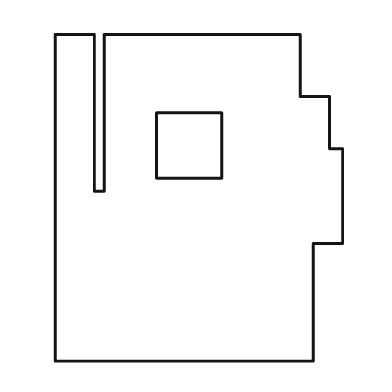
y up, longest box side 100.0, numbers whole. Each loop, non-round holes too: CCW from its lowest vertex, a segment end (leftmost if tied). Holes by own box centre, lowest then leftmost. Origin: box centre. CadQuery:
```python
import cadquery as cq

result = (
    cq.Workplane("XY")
    .moveTo(-44.0, -50.0)
    .lineTo(35.0, -50.0)
    .lineTo(35.0, -14.0)
    .lineTo(44.0, -14.0)
    .lineTo(44.0, 15.0)
    .lineTo(40.0, 15.0)
    .lineTo(40.0, 31.0)
    .lineTo(31.0, 31.0)
    .lineTo(31.0, 50.0)
    .lineTo(-29.0, 50.0)
    .lineTo(-29.0, 2.0)
    .lineTo(-32.0, 2.0)
    .lineTo(-32.0, 50.0)
    .lineTo(-44.0, 50.0)
    .close()
    .moveTo(-13.0, 6.0)
    .lineTo(7.0, 6.0)
    .lineTo(7.0, 26.0)
    .lineTo(-13.0, 26.0)
    .close()
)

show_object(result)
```